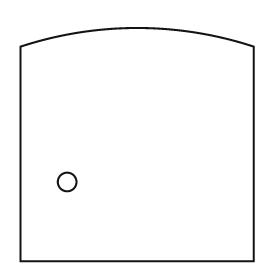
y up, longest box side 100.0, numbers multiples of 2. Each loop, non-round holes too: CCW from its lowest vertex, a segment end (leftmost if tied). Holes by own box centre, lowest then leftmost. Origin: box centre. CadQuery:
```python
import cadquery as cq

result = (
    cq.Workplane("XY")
    .moveTo(-50.0, -50.0)
    .lineTo(50.0, -50.0)
    .lineTo(50.0, 42.0)
    .threePointArc((0.0, 50.0), (-50.0, 42.0))
    .close()
    .moveTo(-30.0, -16.0)
    .circle(4.0)
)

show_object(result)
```